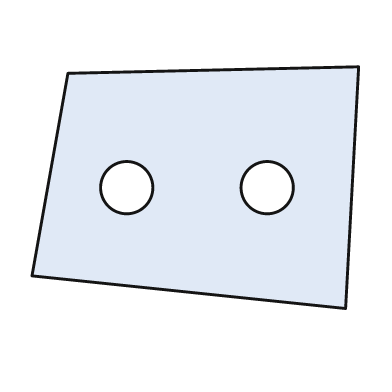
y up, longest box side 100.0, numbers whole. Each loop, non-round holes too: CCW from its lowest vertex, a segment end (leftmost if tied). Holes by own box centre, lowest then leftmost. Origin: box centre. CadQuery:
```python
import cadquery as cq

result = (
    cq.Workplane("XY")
    .moveTo(46.0, -37.0)
    .lineTo(50.0, 37.0)
    .lineTo(-39.0, 35.0)
    .lineTo(-50.0, -27.0)
    .close()
    .moveTo(-21.0, 0.0)
    .circle(8.0)
    .moveTo(22.0, 0.0)
    .circle(8.0)
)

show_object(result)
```